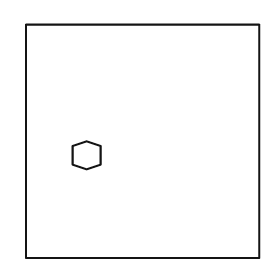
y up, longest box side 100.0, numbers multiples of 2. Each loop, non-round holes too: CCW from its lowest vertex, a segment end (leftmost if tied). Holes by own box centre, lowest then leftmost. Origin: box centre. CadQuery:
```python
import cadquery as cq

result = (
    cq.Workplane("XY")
    .moveTo(-50.0, -50.0)
    .lineTo(50.0, -50.0)
    .lineTo(50.0, 50.0)
    .lineTo(-50.0, 50.0)
    .close()
    .moveTo(-24.0, -12.0)
    .lineTo(-18.0, -10.0)
    .lineTo(-18.0, -2.0)
    .lineTo(-24.0, 0.0)
    .lineTo(-30.0, -2.0)
    .lineTo(-30.0, -10.0)
    .close()
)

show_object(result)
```